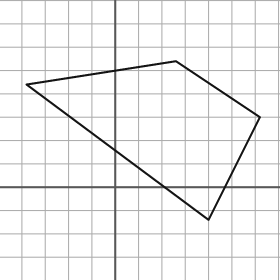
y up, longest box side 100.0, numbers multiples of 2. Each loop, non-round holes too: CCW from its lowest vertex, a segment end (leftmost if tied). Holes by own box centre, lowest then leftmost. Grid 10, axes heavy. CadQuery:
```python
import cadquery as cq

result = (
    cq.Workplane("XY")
    .moveTo(40.0, -14.0)
    .lineTo(62.0, 30.0)
    .lineTo(26.0, 54.0)
    .lineTo(-38.0, 44.0)
    .close()
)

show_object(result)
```